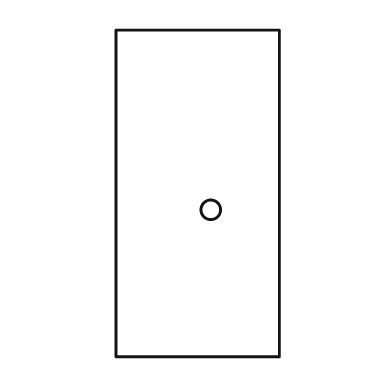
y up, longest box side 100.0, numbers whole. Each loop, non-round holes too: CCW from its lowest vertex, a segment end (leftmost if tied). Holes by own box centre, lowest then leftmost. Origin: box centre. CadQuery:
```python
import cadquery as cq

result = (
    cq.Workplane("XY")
    .moveTo(-25.0, -50.0)
    .lineTo(25.0, -50.0)
    .lineTo(25.0, 50.0)
    .lineTo(-25.0, 50.0)
    .close()
    .moveTo(4.0, -5.0)
    .circle(3.0)
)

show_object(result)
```